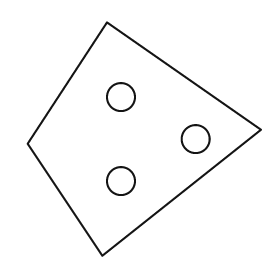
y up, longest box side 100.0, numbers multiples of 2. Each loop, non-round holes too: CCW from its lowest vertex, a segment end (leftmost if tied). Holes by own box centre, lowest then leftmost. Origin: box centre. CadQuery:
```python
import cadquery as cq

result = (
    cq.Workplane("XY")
    .moveTo(-18.0, -50.0)
    .lineTo(50.0, 4.0)
    .lineTo(-16.0, 50.0)
    .lineTo(-50.0, -2.0)
    .close()
    .moveTo(-10.0, -18.0)
    .circle(6.0)
    .moveTo(22.0, 0.0)
    .circle(6.0)
    .moveTo(-10.0, 18.0)
    .circle(6.0)
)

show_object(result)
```